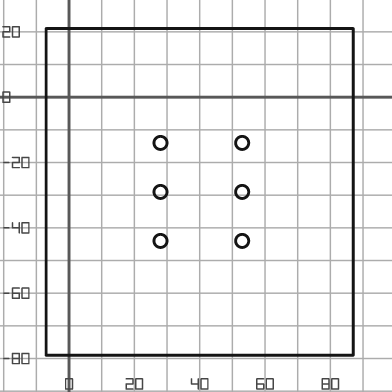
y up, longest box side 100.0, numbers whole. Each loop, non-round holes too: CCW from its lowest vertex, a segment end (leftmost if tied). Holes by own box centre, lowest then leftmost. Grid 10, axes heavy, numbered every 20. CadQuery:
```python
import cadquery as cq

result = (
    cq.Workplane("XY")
    .moveTo(-7.0, -79.0)
    .lineTo(87.0, -79.0)
    .lineTo(87.0, 21.0)
    .lineTo(-7.0, 21.0)
    .close()
    .moveTo(28.0, -44.0)
    .circle(2.0)
    .moveTo(53.0, -44.0)
    .circle(2.0)
    .moveTo(28.0, -29.0)
    .circle(2.0)
    .moveTo(53.0, -29.0)
    .circle(2.0)
    .moveTo(28.0, -14.0)
    .circle(2.0)
    .moveTo(53.0, -14.0)
    .circle(2.0)
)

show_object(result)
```